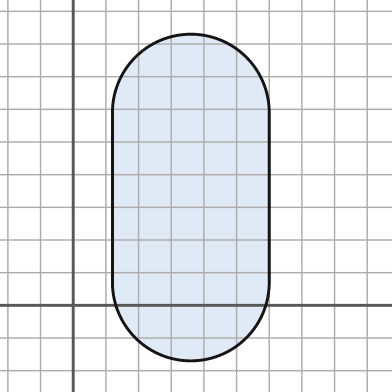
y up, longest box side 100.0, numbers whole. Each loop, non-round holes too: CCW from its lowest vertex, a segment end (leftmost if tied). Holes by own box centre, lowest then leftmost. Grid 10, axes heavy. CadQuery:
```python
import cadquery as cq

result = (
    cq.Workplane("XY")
    .moveTo(12.0, 7.0)
    .threePointArc((36.0, -17.0), (60.0, 7.0))
    .lineTo(60.0, 59.0)
    .threePointArc((36.0, 83.0), (12.0, 59.0))
    .close()
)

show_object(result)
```